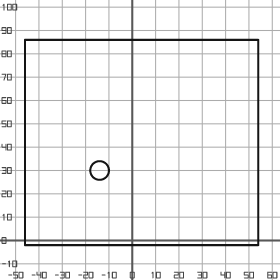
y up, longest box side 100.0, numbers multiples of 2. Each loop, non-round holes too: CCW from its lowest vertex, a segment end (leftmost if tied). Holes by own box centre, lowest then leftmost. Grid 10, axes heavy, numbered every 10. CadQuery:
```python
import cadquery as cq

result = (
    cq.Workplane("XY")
    .moveTo(-46.0, -2.0)
    .lineTo(54.0, -2.0)
    .lineTo(54.0, 86.0)
    .lineTo(-46.0, 86.0)
    .close()
    .moveTo(-14.0, 30.0)
    .circle(4.0)
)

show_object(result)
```